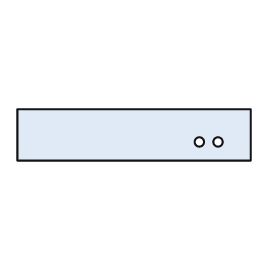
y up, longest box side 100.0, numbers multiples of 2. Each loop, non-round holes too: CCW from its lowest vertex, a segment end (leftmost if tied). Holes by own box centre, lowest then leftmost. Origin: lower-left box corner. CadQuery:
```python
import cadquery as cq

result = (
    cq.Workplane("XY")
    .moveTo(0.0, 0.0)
    .lineTo(100.0, 0.0)
    .lineTo(100.0, 22.0)
    .lineTo(0.0, 22.0)
    .close()
    .moveTo(78.0, 8.0)
    .circle(2.0)
    .moveTo(86.0, 8.0)
    .circle(2.0)
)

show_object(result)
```